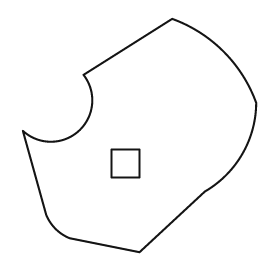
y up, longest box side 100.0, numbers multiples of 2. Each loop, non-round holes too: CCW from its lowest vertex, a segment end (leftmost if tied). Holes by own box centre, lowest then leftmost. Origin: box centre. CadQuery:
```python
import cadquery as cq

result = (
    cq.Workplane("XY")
    .moveTo(0.0, -50.0)
    .lineTo(28.0, -24.0)
    .threePointArc((44.0, -8.0), (50.0, 14.0))
    .threePointArc((36.0, 36.0), (14.0, 50.0))
    .lineTo(-24.0, 26.0)
    .threePointArc((-26.0, 2.0), (-50.0, 2.0))
    .lineTo(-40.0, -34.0)
    .threePointArc((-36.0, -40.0), (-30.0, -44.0))
    .close()
    .moveTo(-12.0, -18.0)
    .lineTo(0.0, -18.0)
    .lineTo(0.0, -6.0)
    .lineTo(-12.0, -6.0)
    .close()
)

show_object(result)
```